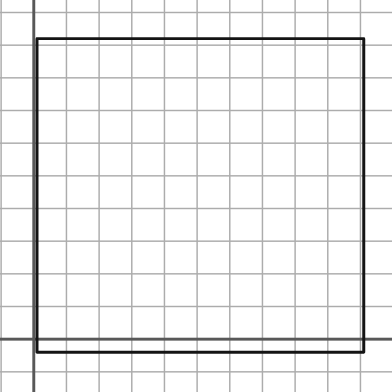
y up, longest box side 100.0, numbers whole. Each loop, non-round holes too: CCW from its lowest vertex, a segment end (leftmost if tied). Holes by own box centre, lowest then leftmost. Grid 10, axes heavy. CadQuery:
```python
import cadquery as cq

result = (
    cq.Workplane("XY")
    .moveTo(1.0, -4.0)
    .lineTo(101.0, -4.0)
    .lineTo(101.0, 92.0)
    .lineTo(1.0, 92.0)
    .close()
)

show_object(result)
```